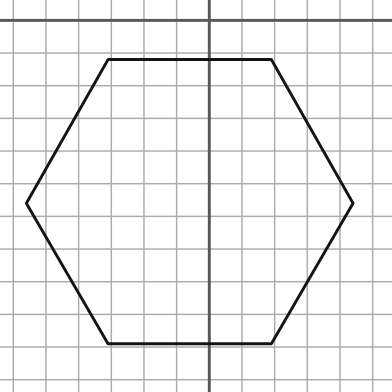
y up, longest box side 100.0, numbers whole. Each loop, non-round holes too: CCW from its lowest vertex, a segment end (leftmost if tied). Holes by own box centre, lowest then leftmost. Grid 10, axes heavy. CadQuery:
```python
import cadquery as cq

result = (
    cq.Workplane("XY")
    .moveTo(-31.0, -99.0)
    .lineTo(19.0, -99.0)
    .lineTo(44.0, -56.0)
    .lineTo(19.0, -12.0)
    .lineTo(-31.0, -12.0)
    .lineTo(-56.0, -56.0)
    .close()
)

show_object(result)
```